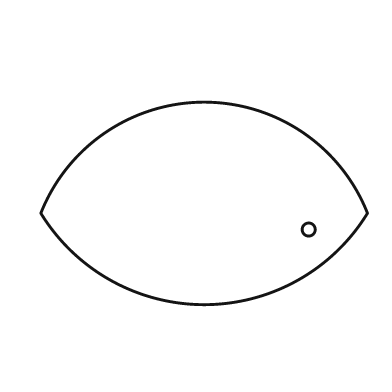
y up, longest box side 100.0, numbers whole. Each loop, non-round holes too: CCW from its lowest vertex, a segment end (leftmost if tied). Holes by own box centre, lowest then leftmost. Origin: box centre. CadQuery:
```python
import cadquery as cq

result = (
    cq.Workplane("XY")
    .moveTo(-50.0, -3.0)
    .threePointArc((0.0, -31.0), (50.0, -3.0))
    .threePointArc((0.0, 31.0), (-50.0, -3.0))
    .close()
    .moveTo(32.0, -8.0)
    .circle(2.0)
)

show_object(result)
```